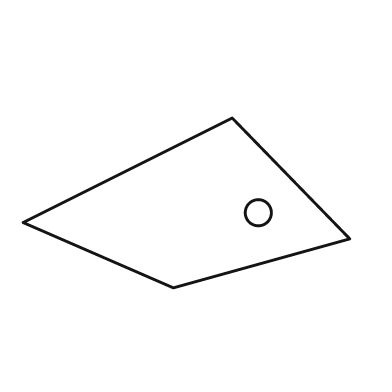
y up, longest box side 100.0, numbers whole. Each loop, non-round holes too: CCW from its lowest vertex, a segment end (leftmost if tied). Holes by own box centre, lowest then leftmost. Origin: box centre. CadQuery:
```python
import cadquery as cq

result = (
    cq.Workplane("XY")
    .moveTo(-4.0, -26.0)
    .lineTo(50.0, -11.0)
    .lineTo(14.0, 26.0)
    .lineTo(-50.0, -6.0)
    .close()
    .moveTo(22.0, -3.0)
    .circle(4.0)
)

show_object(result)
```